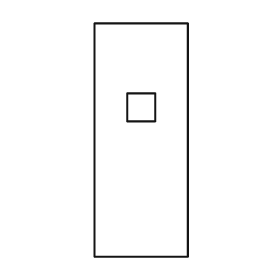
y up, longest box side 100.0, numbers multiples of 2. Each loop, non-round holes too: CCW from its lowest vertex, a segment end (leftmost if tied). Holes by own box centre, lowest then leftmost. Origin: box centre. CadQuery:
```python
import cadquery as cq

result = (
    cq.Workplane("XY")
    .moveTo(-20.0, -50.0)
    .lineTo(20.0, -50.0)
    .lineTo(20.0, 50.0)
    .lineTo(-20.0, 50.0)
    .close()
    .moveTo(-6.0, 8.0)
    .lineTo(6.0, 8.0)
    .lineTo(6.0, 20.0)
    .lineTo(-6.0, 20.0)
    .close()
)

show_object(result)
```